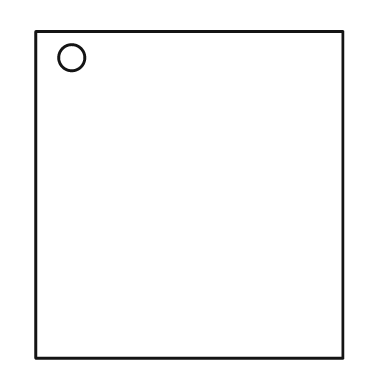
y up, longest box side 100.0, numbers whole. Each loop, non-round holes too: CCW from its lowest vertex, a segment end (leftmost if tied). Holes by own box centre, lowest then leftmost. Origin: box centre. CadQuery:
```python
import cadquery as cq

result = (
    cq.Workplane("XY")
    .moveTo(-47.0, -50.0)
    .lineTo(47.0, -50.0)
    .lineTo(47.0, 50.0)
    .lineTo(-47.0, 50.0)
    .close()
    .moveTo(-36.0, 42.0)
    .circle(4.0)
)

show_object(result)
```